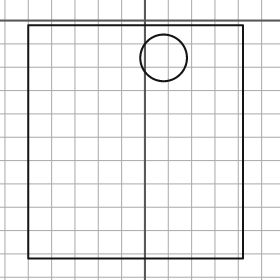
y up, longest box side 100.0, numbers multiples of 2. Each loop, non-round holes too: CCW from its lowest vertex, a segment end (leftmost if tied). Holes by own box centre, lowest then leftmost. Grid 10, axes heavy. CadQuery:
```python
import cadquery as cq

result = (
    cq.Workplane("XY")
    .moveTo(-50.0, -102.0)
    .lineTo(42.0, -102.0)
    .lineTo(42.0, -2.0)
    .lineTo(-50.0, -2.0)
    .close()
    .moveTo(8.0, -16.0)
    .circle(10.0)
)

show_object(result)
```